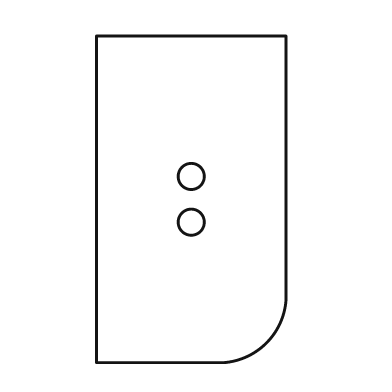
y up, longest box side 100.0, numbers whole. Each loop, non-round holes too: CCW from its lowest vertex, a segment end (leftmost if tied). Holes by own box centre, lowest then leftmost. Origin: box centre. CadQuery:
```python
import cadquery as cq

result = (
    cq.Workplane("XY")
    .moveTo(-29.0, -50.0)
    .lineTo(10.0, -50.0)
    .threePointArc((23.0, -44.0), (29.0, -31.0))
    .lineTo(29.0, 50.0)
    .lineTo(-29.0, 50.0)
    .close()
    .moveTo(0.0, -7.0)
    .circle(4.0)
    .moveTo(0.0, 7.0)
    .circle(4.0)
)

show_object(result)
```